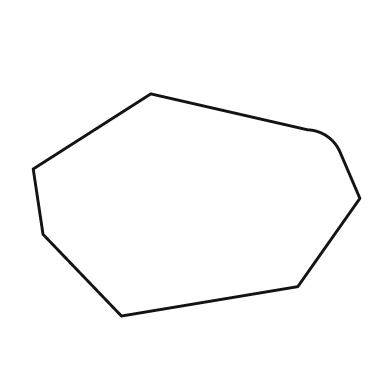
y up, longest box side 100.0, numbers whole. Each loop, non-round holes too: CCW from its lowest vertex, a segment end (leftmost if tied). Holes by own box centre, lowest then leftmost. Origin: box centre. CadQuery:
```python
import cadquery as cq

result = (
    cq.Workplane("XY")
    .moveTo(-23.0, -34.0)
    .lineTo(31.0, -25.0)
    .lineTo(50.0, 2.0)
    .lineTo(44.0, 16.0)
    .threePointArc((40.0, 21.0), (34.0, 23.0))
    .lineTo(-14.0, 34.0)
    .lineTo(-50.0, 11.0)
    .lineTo(-47.0, -9.0)
    .close()
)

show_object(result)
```